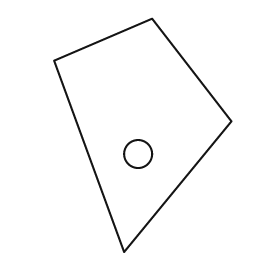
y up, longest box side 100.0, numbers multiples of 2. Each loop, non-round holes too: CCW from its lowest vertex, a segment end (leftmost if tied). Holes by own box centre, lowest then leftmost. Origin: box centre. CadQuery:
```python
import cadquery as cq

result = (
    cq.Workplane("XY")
    .moveTo(-8.0, -50.0)
    .lineTo(38.0, 6.0)
    .lineTo(4.0, 50.0)
    .lineTo(-38.0, 32.0)
    .close()
    .moveTo(-2.0, -8.0)
    .circle(6.0)
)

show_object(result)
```